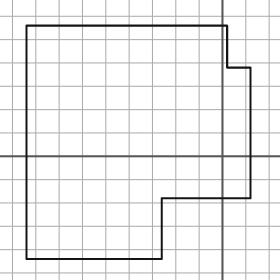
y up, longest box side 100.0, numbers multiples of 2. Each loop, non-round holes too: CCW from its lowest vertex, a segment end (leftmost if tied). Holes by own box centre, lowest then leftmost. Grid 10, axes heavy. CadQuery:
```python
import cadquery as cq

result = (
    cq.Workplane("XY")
    .moveTo(-84.0, -44.0)
    .lineTo(-26.0, -44.0)
    .lineTo(-26.0, -18.0)
    .lineTo(12.0, -18.0)
    .lineTo(12.0, 38.0)
    .lineTo(2.0, 38.0)
    .lineTo(2.0, 56.0)
    .lineTo(-84.0, 56.0)
    .close()
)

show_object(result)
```